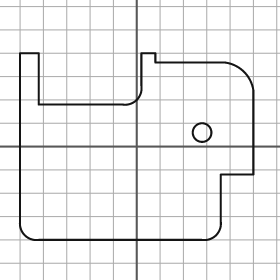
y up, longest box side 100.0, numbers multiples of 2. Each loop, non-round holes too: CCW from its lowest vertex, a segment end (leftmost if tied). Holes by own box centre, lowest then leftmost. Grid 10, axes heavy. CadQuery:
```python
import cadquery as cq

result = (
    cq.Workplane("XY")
    .moveTo(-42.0, -40.0)
    .lineTo(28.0, -40.0)
    .threePointArc((34.0, -38.0), (36.0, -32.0))
    .lineTo(36.0, -12.0)
    .lineTo(50.0, -12.0)
    .lineTo(50.0, 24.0)
    .threePointArc((46.0, 32.0), (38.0, 36.0))
    .lineTo(8.0, 36.0)
    .lineTo(8.0, 40.0)
    .lineTo(2.0, 40.0)
    .lineTo(2.0, 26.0)
    .threePointArc((0.0, 20.0), (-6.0, 18.0))
    .lineTo(-42.0, 18.0)
    .lineTo(-42.0, 40.0)
    .lineTo(-50.0, 40.0)
    .lineTo(-50.0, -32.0)
    .threePointArc((-48.0, -38.0), (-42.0, -40.0))
    .close()
    .moveTo(28.0, 6.0)
    .circle(4.0)
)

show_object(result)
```